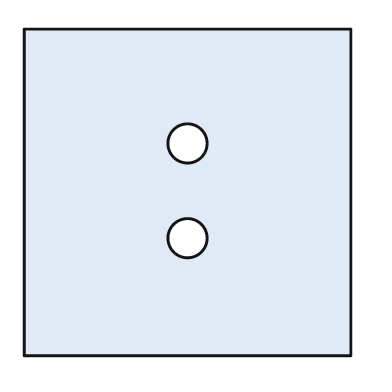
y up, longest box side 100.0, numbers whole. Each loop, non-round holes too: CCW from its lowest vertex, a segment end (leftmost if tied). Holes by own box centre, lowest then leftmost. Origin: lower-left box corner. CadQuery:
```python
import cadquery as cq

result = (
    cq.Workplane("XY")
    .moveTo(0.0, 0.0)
    .lineTo(100.0, 0.0)
    .lineTo(100.0, 100.0)
    .lineTo(0.0, 100.0)
    .close()
    .moveTo(50.0, 36.0)
    .circle(6.0)
    .moveTo(50.0, 65.0)
    .circle(6.0)
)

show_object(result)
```